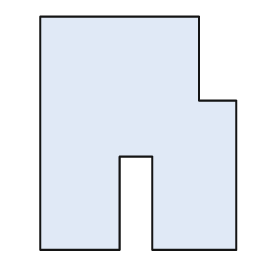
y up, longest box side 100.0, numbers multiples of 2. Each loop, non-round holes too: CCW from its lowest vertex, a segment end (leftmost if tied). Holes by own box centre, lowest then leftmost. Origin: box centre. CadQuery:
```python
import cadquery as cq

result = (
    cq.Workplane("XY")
    .moveTo(-42.0, -50.0)
    .lineTo(-8.0, -50.0)
    .lineTo(-8.0, -10.0)
    .lineTo(6.0, -10.0)
    .lineTo(6.0, -50.0)
    .lineTo(42.0, -50.0)
    .lineTo(42.0, 14.0)
    .lineTo(26.0, 14.0)
    .lineTo(26.0, 50.0)
    .lineTo(-42.0, 50.0)
    .close()
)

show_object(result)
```